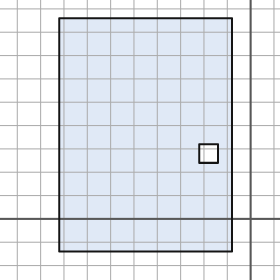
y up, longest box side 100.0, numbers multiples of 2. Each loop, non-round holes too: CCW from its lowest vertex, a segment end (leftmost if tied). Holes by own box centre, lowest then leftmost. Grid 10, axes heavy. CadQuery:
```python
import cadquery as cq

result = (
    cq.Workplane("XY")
    .moveTo(-82.0, -14.0)
    .lineTo(-8.0, -14.0)
    .lineTo(-8.0, 86.0)
    .lineTo(-82.0, 86.0)
    .close()
    .moveTo(-22.0, 24.0)
    .lineTo(-14.0, 24.0)
    .lineTo(-14.0, 32.0)
    .lineTo(-22.0, 32.0)
    .close()
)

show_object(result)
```